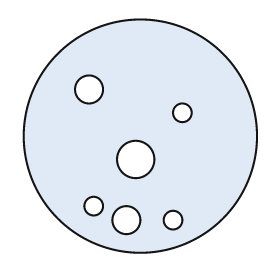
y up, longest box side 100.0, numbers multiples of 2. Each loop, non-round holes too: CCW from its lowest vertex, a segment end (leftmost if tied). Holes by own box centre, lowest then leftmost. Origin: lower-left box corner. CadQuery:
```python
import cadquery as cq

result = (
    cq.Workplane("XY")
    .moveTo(50.0, 50.0)
    .circle(50.0)
    .moveTo(44.0, 14.0)
    .circle(6.0)
    .moveTo(64.0, 14.0)
    .circle(4.0)
    .moveTo(30.0, 20.0)
    .circle(4.0)
    .moveTo(48.0, 40.0)
    .circle(8.0)
    .moveTo(68.0, 60.0)
    .circle(4.0)
    .moveTo(28.0, 70.0)
    .circle(6.0)
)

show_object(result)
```